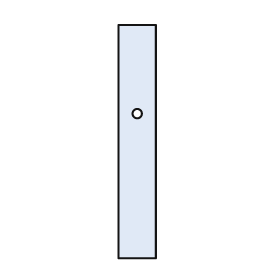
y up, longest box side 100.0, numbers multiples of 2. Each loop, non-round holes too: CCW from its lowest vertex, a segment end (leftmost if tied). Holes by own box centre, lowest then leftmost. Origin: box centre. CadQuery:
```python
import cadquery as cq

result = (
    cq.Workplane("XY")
    .moveTo(-8.0, -50.0)
    .lineTo(8.0, -50.0)
    .lineTo(8.0, 50.0)
    .lineTo(-8.0, 50.0)
    .close()
    .moveTo(0.0, 12.0)
    .circle(2.0)
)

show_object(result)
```